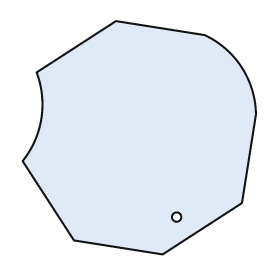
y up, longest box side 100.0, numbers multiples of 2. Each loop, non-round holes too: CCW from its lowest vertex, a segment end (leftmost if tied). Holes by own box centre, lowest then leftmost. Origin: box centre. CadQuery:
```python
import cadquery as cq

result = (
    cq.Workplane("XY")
    .moveTo(10.0, -50.0)
    .lineTo(44.0, -28.0)
    .lineTo(50.0, 10.0)
    .threePointArc((44.0, 30.0), (28.0, 44.0))
    .lineTo(-10.0, 50.0)
    .lineTo(-44.0, 28.0)
    .threePointArc((-42.0, 8.0), (-50.0, -10.0))
    .lineTo(-28.0, -44.0)
    .close()
    .moveTo(16.0, -34.0)
    .circle(2.0)
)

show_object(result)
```